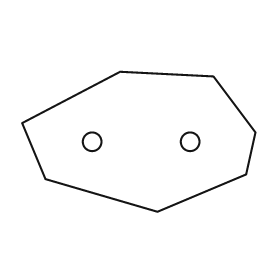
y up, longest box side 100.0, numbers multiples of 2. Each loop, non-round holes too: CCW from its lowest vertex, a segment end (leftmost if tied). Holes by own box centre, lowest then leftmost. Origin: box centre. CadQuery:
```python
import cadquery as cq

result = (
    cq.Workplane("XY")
    .moveTo(8.0, -30.0)
    .lineTo(46.0, -14.0)
    .lineTo(50.0, 4.0)
    .lineTo(32.0, 28.0)
    .lineTo(-8.0, 30.0)
    .lineTo(-50.0, 8.0)
    .lineTo(-40.0, -16.0)
    .close()
    .moveTo(-20.0, 0.0)
    .circle(4.0)
    .moveTo(22.0, 0.0)
    .circle(4.0)
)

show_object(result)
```